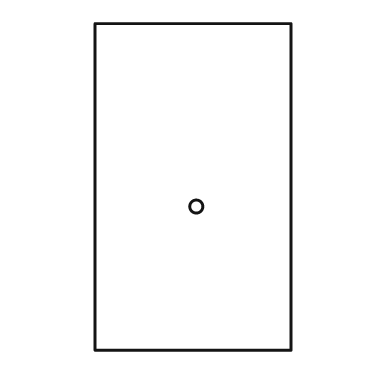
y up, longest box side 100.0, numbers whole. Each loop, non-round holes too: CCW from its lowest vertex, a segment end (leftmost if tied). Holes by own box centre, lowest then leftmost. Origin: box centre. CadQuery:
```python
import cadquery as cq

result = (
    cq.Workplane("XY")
    .moveTo(-30.0, -50.0)
    .lineTo(30.0, -50.0)
    .lineTo(30.0, 50.0)
    .lineTo(-30.0, 50.0)
    .close()
    .moveTo(1.0, -6.0)
    .circle(2.0)
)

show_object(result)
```